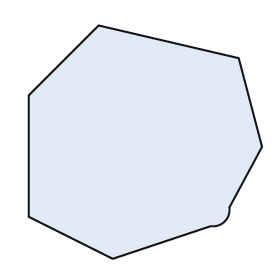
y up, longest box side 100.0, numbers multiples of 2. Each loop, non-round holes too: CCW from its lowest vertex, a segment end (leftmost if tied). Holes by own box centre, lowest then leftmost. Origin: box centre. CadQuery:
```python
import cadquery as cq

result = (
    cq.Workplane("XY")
    .moveTo(-14.0, -50.0)
    .lineTo(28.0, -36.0)
    .threePointArc((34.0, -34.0), (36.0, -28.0))
    .lineTo(50.0, -2.0)
    .lineTo(40.0, 36.0)
    .lineTo(-20.0, 50.0)
    .lineTo(-50.0, 20.0)
    .lineTo(-50.0, -32.0)
    .close()
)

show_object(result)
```